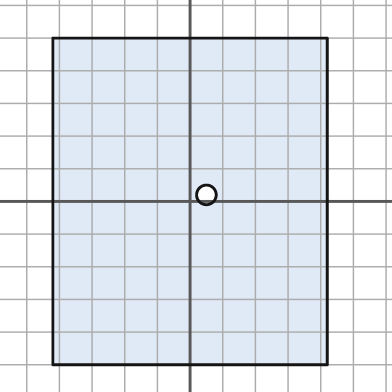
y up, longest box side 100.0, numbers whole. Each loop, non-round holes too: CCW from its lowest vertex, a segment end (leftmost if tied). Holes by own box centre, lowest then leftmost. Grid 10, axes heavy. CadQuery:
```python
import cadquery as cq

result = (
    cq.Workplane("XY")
    .moveTo(-42.0, -50.0)
    .lineTo(42.0, -50.0)
    .lineTo(42.0, 50.0)
    .lineTo(-42.0, 50.0)
    .close()
    .moveTo(5.0, 2.0)
    .circle(3.0)
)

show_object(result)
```